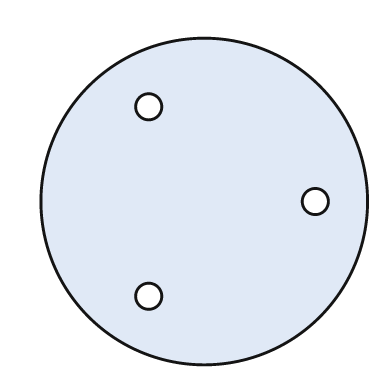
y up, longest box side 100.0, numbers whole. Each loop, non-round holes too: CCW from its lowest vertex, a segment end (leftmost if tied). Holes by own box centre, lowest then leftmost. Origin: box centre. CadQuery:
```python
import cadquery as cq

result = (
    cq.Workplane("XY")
    .moveTo(0.0, 0.0)
    .circle(50.0)
    .moveTo(-17.0, -29.0)
    .circle(4.0)
    .moveTo(34.0, 0.0)
    .circle(4.0)
    .moveTo(-17.0, 29.0)
    .circle(4.0)
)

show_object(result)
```